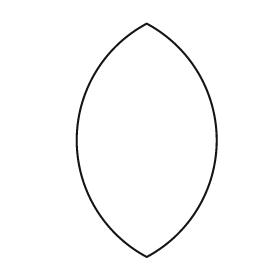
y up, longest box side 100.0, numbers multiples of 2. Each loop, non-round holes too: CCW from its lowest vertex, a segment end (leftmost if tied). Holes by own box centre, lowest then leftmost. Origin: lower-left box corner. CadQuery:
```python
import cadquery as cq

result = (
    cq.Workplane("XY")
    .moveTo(30.0, 0.0)
    .threePointArc((60.0, 50.0), (30.0, 100.0))
    .threePointArc((0.0, 50.0), (30.0, 0.0))
    .close()
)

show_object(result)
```